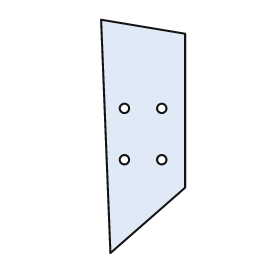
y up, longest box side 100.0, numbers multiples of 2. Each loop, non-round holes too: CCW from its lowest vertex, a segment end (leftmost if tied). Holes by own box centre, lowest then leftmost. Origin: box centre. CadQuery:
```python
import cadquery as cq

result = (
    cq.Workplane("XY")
    .moveTo(-14.0, -50.0)
    .lineTo(18.0, -22.0)
    .lineTo(18.0, 44.0)
    .lineTo(-18.0, 50.0)
    .close()
    .moveTo(-8.0, -10.0)
    .circle(2.0)
    .moveTo(8.0, -10.0)
    .circle(2.0)
    .moveTo(-8.0, 12.0)
    .circle(2.0)
    .moveTo(8.0, 12.0)
    .circle(2.0)
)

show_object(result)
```